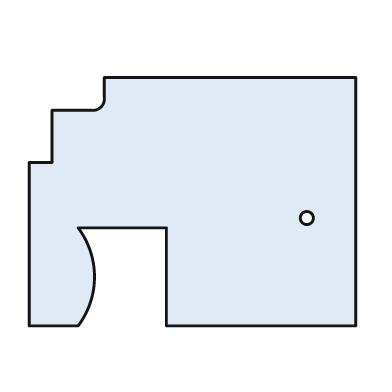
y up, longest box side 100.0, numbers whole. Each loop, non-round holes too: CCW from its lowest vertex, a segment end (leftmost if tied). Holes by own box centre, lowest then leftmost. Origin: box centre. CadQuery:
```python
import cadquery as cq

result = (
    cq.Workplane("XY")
    .moveTo(-50.0, -38.0)
    .lineTo(-35.0, -38.0)
    .threePointArc((-30.0, -23.0), (-35.0, -8.0))
    .lineTo(-8.0, -8.0)
    .lineTo(-8.0, -38.0)
    .lineTo(50.0, -38.0)
    .lineTo(50.0, 38.0)
    .lineTo(-27.0, 38.0)
    .lineTo(-27.0, 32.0)
    .threePointArc((-28.0, 29.0), (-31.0, 28.0))
    .lineTo(-43.0, 28.0)
    .lineTo(-43.0, 12.0)
    .lineTo(-50.0, 12.0)
    .close()
    .moveTo(35.0, -5.0)
    .circle(2.0)
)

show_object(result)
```